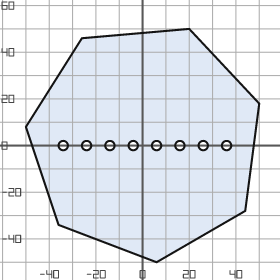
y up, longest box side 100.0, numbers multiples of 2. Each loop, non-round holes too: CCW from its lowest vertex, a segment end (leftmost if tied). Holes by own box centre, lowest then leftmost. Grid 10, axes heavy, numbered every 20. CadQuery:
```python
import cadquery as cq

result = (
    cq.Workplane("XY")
    .moveTo(6.0, -50.0)
    .lineTo(44.0, -28.0)
    .lineTo(50.0, 18.0)
    .lineTo(20.0, 50.0)
    .lineTo(-26.0, 46.0)
    .lineTo(-50.0, 8.0)
    .lineTo(-36.0, -34.0)
    .close()
    .moveTo(-34.0, 0.0)
    .circle(2.0)
    .moveTo(-24.0, 0.0)
    .circle(2.0)
    .moveTo(-14.0, 0.0)
    .circle(2.0)
    .moveTo(-4.0, 0.0)
    .circle(2.0)
    .moveTo(6.0, 0.0)
    .circle(2.0)
    .moveTo(16.0, 0.0)
    .circle(2.0)
    .moveTo(26.0, 0.0)
    .circle(2.0)
    .moveTo(36.0, 0.0)
    .circle(2.0)
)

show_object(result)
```